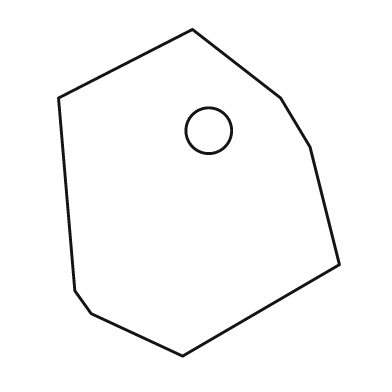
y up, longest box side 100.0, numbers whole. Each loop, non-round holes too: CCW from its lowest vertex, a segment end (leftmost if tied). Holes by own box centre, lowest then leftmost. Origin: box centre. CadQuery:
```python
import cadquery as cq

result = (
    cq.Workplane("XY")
    .moveTo(-5.0, -50.0)
    .lineTo(43.0, -22.0)
    .lineTo(34.0, 14.0)
    .lineTo(25.0, 29.0)
    .lineTo(-2.0, 50.0)
    .lineTo(-43.0, 29.0)
    .lineTo(-38.0, -30.0)
    .lineTo(-33.0, -37.0)
    .close()
    .moveTo(3.0, 19.0)
    .circle(7.0)
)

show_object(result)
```